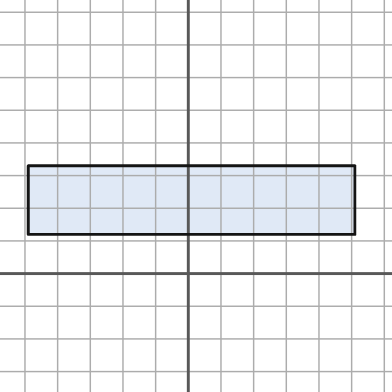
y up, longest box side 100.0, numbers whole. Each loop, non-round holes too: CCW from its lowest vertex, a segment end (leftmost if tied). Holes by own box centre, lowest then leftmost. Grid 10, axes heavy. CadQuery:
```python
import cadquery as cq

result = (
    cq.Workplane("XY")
    .moveTo(-49.0, 12.0)
    .lineTo(51.0, 12.0)
    .lineTo(51.0, 33.0)
    .lineTo(-49.0, 33.0)
    .close()
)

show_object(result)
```